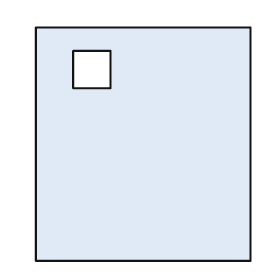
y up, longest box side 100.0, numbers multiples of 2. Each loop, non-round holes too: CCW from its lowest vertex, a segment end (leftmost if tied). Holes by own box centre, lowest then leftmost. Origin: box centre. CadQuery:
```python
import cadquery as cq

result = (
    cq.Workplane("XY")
    .moveTo(-46.0, -50.0)
    .lineTo(46.0, -50.0)
    .lineTo(46.0, 50.0)
    .lineTo(-46.0, 50.0)
    .close()
    .moveTo(-30.0, 24.0)
    .lineTo(-14.0, 24.0)
    .lineTo(-14.0, 40.0)
    .lineTo(-30.0, 40.0)
    .close()
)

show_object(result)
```